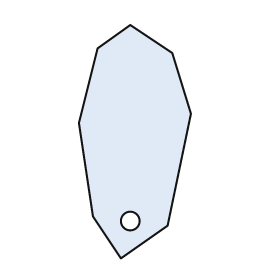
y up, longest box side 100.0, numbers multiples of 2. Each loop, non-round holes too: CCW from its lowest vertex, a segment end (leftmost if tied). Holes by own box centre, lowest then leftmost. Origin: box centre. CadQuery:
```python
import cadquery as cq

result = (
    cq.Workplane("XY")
    .moveTo(-6.0, -50.0)
    .lineTo(14.0, -36.0)
    .lineTo(24.0, 12.0)
    .lineTo(16.0, 38.0)
    .lineTo(-2.0, 50.0)
    .lineTo(-16.0, 40.0)
    .lineTo(-24.0, 8.0)
    .lineTo(-18.0, -32.0)
    .close()
    .moveTo(-2.0, -34.0)
    .circle(4.0)
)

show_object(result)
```